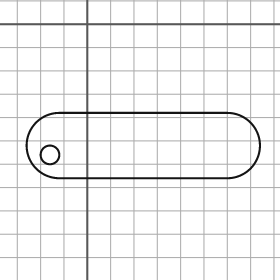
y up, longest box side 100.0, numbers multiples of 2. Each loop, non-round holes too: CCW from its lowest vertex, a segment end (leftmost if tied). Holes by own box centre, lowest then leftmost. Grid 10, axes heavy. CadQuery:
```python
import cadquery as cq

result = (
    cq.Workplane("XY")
    .moveTo(-12.0, -66.0)
    .lineTo(60.0, -66.0)
    .threePointArc((74.0, -52.0), (60.0, -38.0))
    .lineTo(-12.0, -38.0)
    .threePointArc((-26.0, -52.0), (-12.0, -66.0))
    .close()
    .moveTo(-16.0, -56.0)
    .circle(4.0)
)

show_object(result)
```